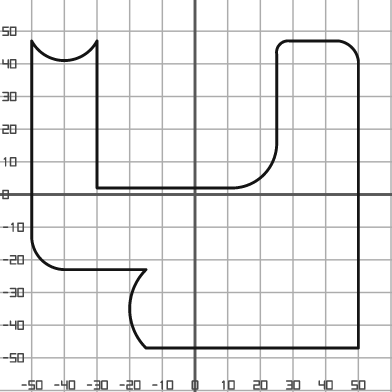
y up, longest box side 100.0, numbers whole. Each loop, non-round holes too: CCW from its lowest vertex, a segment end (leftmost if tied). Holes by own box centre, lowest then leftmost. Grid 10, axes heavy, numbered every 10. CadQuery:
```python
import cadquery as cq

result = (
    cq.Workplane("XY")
    .moveTo(-15.0, -47.0)
    .lineTo(50.0, -47.0)
    .lineTo(50.0, 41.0)
    .threePointArc((48.0, 45.0), (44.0, 47.0))
    .lineTo(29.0, 47.0)
    .threePointArc((26.0, 46.0), (25.0, 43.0))
    .lineTo(25.0, 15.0)
    .threePointArc((21.0, 6.0), (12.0, 2.0))
    .lineTo(-30.0, 2.0)
    .lineTo(-30.0, 47.0)
    .threePointArc((-40.0, 41.0), (-50.0, 47.0))
    .lineTo(-50.0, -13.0)
    .threePointArc((-47.0, -20.0), (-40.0, -23.0))
    .lineTo(-15.0, -23.0)
    .threePointArc((-20.0, -35.0), (-15.0, -47.0))
    .close()
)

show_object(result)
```